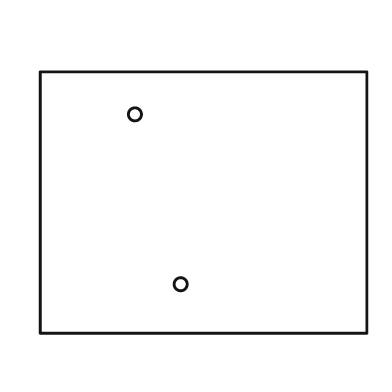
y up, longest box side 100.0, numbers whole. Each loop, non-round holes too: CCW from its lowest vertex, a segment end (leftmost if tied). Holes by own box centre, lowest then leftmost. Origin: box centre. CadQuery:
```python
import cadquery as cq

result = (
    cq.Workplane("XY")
    .moveTo(-50.0, -40.0)
    .lineTo(50.0, -40.0)
    .lineTo(50.0, 40.0)
    .lineTo(-50.0, 40.0)
    .close()
    .moveTo(-7.0, -25.0)
    .circle(2.0)
    .moveTo(-21.0, 27.0)
    .circle(2.0)
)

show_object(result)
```